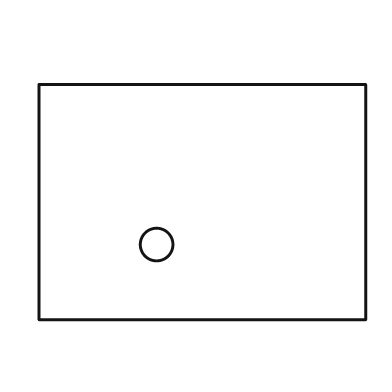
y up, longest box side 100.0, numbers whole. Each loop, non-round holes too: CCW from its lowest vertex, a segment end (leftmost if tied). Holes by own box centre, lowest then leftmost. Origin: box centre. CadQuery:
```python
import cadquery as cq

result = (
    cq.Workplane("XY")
    .moveTo(-50.0, -36.0)
    .lineTo(50.0, -36.0)
    .lineTo(50.0, 36.0)
    .lineTo(-50.0, 36.0)
    .close()
    .moveTo(-14.0, -13.0)
    .circle(5.0)
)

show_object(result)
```